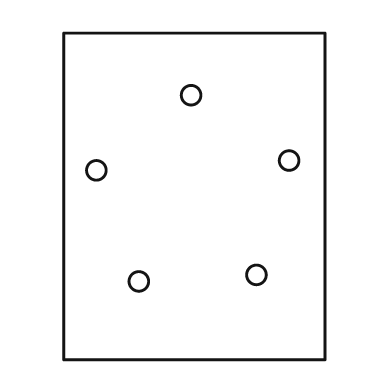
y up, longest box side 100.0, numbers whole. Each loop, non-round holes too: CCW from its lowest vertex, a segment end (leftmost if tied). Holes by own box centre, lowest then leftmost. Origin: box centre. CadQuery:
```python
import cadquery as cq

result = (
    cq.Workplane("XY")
    .moveTo(-40.0, -50.0)
    .lineTo(40.0, -50.0)
    .lineTo(40.0, 50.0)
    .lineTo(-40.0, 50.0)
    .close()
    .moveTo(-17.0, -26.0)
    .circle(3.0)
    .moveTo(19.0, -24.0)
    .circle(3.0)
    .moveTo(-30.0, 8.0)
    .circle(3.0)
    .moveTo(29.0, 11.0)
    .circle(3.0)
    .moveTo(-1.0, 31.0)
    .circle(3.0)
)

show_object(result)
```